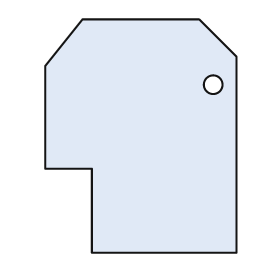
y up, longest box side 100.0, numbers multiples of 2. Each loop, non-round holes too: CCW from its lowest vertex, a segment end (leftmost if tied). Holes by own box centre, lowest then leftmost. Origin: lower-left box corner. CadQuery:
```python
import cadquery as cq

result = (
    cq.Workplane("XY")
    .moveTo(20.0, 0.0)
    .lineTo(82.0, 0.0)
    .lineTo(82.0, 84.0)
    .lineTo(66.0, 100.0)
    .lineTo(16.0, 100.0)
    .lineTo(0.0, 80.0)
    .lineTo(0.0, 36.0)
    .lineTo(20.0, 36.0)
    .close()
    .moveTo(72.0, 72.0)
    .circle(4.0)
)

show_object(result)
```